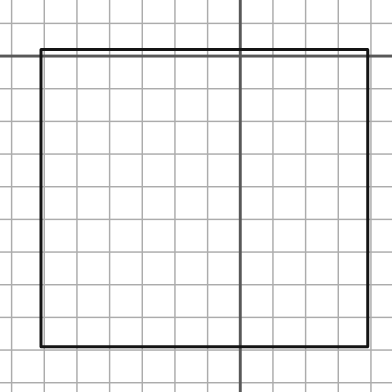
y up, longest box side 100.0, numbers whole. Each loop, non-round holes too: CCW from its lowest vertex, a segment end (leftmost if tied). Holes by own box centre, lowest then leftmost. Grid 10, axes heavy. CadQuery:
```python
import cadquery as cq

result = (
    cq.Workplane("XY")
    .moveTo(-61.0, -89.0)
    .lineTo(39.0, -89.0)
    .lineTo(39.0, 2.0)
    .lineTo(-61.0, 2.0)
    .close()
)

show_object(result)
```